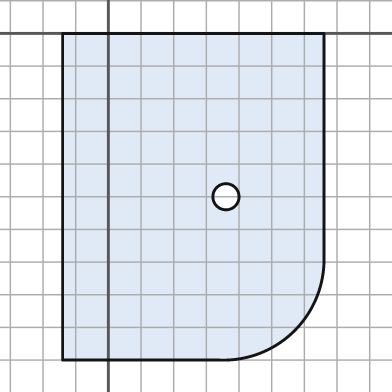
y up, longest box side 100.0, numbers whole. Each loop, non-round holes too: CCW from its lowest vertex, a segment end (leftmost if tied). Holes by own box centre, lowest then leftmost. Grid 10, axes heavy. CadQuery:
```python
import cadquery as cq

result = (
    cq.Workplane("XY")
    .moveTo(-14.0, -100.0)
    .lineTo(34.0, -100.0)
    .threePointArc((57.0, -91.0), (66.0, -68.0))
    .lineTo(66.0, 0.0)
    .lineTo(-14.0, 0.0)
    .close()
    .moveTo(36.0, -50.0)
    .circle(4.0)
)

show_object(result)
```